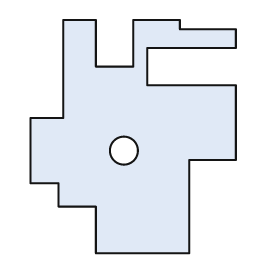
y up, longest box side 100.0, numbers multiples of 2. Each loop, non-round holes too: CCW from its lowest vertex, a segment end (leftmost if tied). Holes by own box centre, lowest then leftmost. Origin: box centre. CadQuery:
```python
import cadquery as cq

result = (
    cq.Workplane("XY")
    .moveTo(-16.0, -50.0)
    .lineTo(24.0, -50.0)
    .lineTo(24.0, -10.0)
    .lineTo(44.0, -10.0)
    .lineTo(44.0, 22.0)
    .lineTo(6.0, 22.0)
    .lineTo(6.0, 38.0)
    .lineTo(44.0, 38.0)
    .lineTo(44.0, 46.0)
    .lineTo(20.0, 46.0)
    .lineTo(20.0, 50.0)
    .lineTo(0.0, 50.0)
    .lineTo(0.0, 30.0)
    .lineTo(-16.0, 30.0)
    .lineTo(-16.0, 50.0)
    .lineTo(-30.0, 50.0)
    .lineTo(-30.0, 8.0)
    .lineTo(-44.0, 8.0)
    .lineTo(-44.0, -20.0)
    .lineTo(-32.0, -20.0)
    .lineTo(-32.0, -30.0)
    .lineTo(-16.0, -30.0)
    .close()
    .moveTo(-4.0, -6.0)
    .circle(6.0)
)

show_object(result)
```